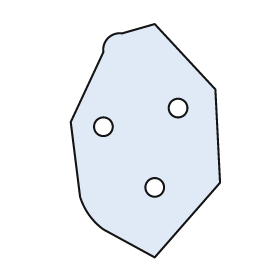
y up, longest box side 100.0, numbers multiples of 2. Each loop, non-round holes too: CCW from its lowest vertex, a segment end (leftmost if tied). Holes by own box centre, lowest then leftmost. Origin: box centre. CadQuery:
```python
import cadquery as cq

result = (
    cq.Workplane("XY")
    .moveTo(4.0, -50.0)
    .lineTo(32.0, -18.0)
    .lineTo(30.0, 22.0)
    .lineTo(4.0, 50.0)
    .lineTo(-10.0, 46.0)
    .threePointArc((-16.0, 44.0), (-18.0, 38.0))
    .lineTo(-32.0, 8.0)
    .lineTo(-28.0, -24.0)
    .threePointArc((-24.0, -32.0), (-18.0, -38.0))
    .close()
    .moveTo(4.0, -20.0)
    .circle(4.0)
    .moveTo(-18.0, 6.0)
    .circle(4.0)
    .moveTo(14.0, 14.0)
    .circle(4.0)
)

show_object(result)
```